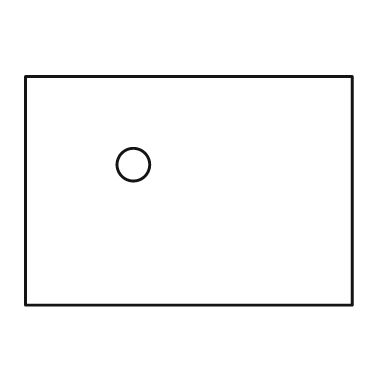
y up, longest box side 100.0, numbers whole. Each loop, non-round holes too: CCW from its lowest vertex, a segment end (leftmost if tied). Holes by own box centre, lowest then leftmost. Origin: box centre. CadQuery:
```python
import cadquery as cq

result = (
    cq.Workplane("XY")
    .moveTo(-50.0, -35.0)
    .lineTo(50.0, -35.0)
    .lineTo(50.0, 35.0)
    .lineTo(-50.0, 35.0)
    .close()
    .moveTo(-17.0, 8.0)
    .circle(5.0)
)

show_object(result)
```